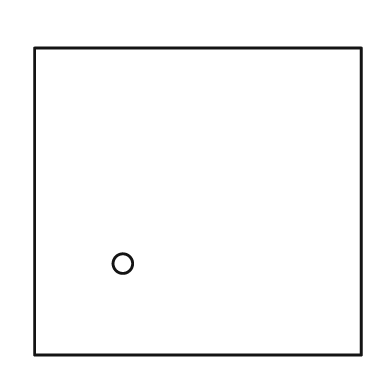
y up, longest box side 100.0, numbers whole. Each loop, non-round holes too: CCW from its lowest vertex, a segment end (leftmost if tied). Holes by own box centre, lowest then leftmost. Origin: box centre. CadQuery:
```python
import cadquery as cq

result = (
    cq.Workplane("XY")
    .moveTo(-50.0, -47.0)
    .lineTo(50.0, -47.0)
    .lineTo(50.0, 47.0)
    .lineTo(-50.0, 47.0)
    .close()
    .moveTo(-23.0, -19.0)
    .circle(3.0)
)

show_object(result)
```